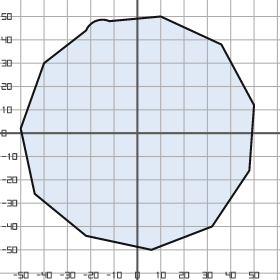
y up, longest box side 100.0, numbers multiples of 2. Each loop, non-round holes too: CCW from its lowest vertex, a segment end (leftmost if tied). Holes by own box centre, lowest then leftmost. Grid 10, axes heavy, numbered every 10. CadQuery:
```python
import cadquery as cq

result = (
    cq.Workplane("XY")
    .moveTo(6.0, -50.0)
    .lineTo(32.0, -40.0)
    .lineTo(48.0, -16.0)
    .lineTo(50.0, 12.0)
    .lineTo(36.0, 38.0)
    .lineTo(10.0, 50.0)
    .lineTo(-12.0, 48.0)
    .threePointArc((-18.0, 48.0), (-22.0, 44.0))
    .lineTo(-40.0, 30.0)
    .lineTo(-50.0, 2.0)
    .lineTo(-44.0, -26.0)
    .lineTo(-22.0, -44.0)
    .close()
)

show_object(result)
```